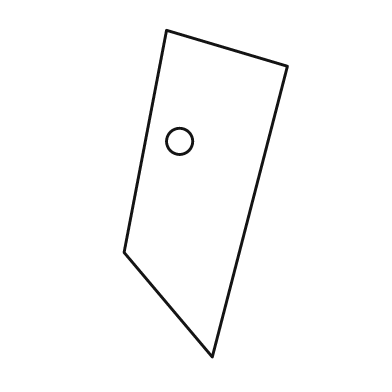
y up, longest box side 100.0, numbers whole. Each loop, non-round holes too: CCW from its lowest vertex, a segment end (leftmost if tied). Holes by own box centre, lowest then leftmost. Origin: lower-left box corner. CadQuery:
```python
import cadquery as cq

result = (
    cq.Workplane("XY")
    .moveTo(27.0, 0.0)
    .lineTo(50.0, 89.0)
    .lineTo(13.0, 100.0)
    .lineTo(0.0, 32.0)
    .close()
    .moveTo(17.0, 66.0)
    .circle(4.0)
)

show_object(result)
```